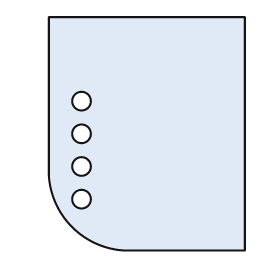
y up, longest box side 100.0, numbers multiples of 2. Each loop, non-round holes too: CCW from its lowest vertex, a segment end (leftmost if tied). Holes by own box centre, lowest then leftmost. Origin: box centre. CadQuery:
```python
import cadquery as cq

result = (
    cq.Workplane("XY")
    .moveTo(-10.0, -50.0)
    .lineTo(42.0, -50.0)
    .lineTo(42.0, 50.0)
    .lineTo(-42.0, 50.0)
    .lineTo(-42.0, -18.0)
    .threePointArc((-32.0, -40.0), (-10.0, -50.0))
    .close()
    .moveTo(-28.0, -28.0)
    .circle(4.0)
    .moveTo(-28.0, -14.0)
    .circle(4.0)
    .moveTo(-28.0, 0.0)
    .circle(4.0)
    .moveTo(-28.0, 14.0)
    .circle(4.0)
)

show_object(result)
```